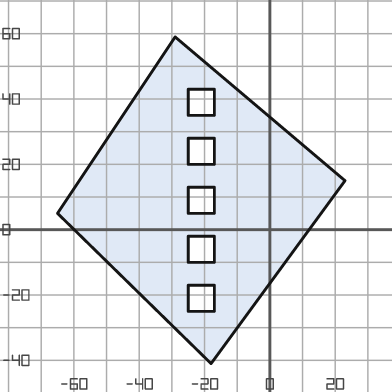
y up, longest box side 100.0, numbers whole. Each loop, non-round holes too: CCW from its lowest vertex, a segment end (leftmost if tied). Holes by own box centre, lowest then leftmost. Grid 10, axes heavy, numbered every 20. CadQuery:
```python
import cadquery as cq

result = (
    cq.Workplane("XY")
    .moveTo(-18.0, -41.0)
    .lineTo(23.0, 15.0)
    .lineTo(-29.0, 59.0)
    .lineTo(-65.0, 5.0)
    .close()
    .moveTo(-25.0, -25.0)
    .lineTo(-17.0, -25.0)
    .lineTo(-17.0, -17.0)
    .lineTo(-25.0, -17.0)
    .close()
    .moveTo(-25.0, -10.0)
    .lineTo(-17.0, -10.0)
    .lineTo(-17.0, -2.0)
    .lineTo(-25.0, -2.0)
    .close()
    .moveTo(-25.0, 5.0)
    .lineTo(-17.0, 5.0)
    .lineTo(-17.0, 13.0)
    .lineTo(-25.0, 13.0)
    .close()
    .moveTo(-25.0, 20.0)
    .lineTo(-17.0, 20.0)
    .lineTo(-17.0, 28.0)
    .lineTo(-25.0, 28.0)
    .close()
    .moveTo(-25.0, 35.0)
    .lineTo(-17.0, 35.0)
    .lineTo(-17.0, 43.0)
    .lineTo(-25.0, 43.0)
    .close()
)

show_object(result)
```